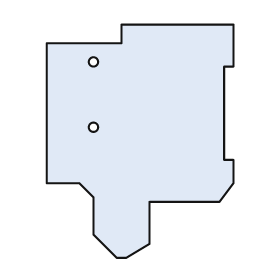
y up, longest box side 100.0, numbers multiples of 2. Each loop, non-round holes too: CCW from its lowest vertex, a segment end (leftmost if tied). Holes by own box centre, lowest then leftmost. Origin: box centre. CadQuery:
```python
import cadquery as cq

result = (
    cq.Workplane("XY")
    .moveTo(-10.0, -50.0)
    .lineTo(-6.0, -50.0)
    .lineTo(4.0, -44.0)
    .lineTo(4.0, -26.0)
    .lineTo(34.0, -26.0)
    .lineTo(40.0, -18.0)
    .lineTo(40.0, -8.0)
    .lineTo(36.0, -8.0)
    .lineTo(36.0, 32.0)
    .lineTo(40.0, 32.0)
    .lineTo(40.0, 50.0)
    .lineTo(-8.0, 50.0)
    .lineTo(-8.0, 42.0)
    .lineTo(-40.0, 42.0)
    .lineTo(-40.0, -18.0)
    .lineTo(-26.0, -18.0)
    .lineTo(-20.0, -24.0)
    .lineTo(-20.0, -40.0)
    .close()
    .moveTo(-20.0, 6.0)
    .circle(2.0)
    .moveTo(-20.0, 34.0)
    .circle(2.0)
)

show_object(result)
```